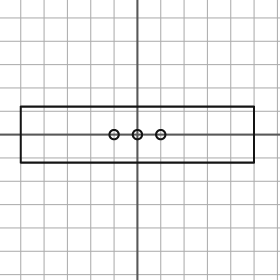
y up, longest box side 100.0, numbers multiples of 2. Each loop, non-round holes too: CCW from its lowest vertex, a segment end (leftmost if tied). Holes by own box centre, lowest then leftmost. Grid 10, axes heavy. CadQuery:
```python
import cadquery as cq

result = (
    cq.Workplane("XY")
    .moveTo(-50.0, -12.0)
    .lineTo(50.0, -12.0)
    .lineTo(50.0, 12.0)
    .lineTo(-50.0, 12.0)
    .close()
    .moveTo(-10.0, 0.0)
    .circle(2.0)
    .moveTo(0.0, 0.0)
    .circle(2.0)
    .moveTo(10.0, 0.0)
    .circle(2.0)
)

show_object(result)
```